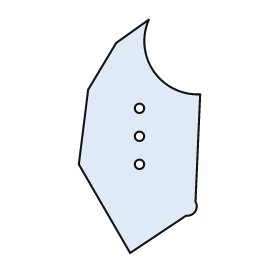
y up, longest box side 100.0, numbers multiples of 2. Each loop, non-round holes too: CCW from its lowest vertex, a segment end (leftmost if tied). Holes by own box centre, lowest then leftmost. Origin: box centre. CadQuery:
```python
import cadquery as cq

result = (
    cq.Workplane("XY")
    .moveTo(-4.0, -50.0)
    .lineTo(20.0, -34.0)
    .threePointArc((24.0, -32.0), (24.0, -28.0))
    .lineTo(26.0, 18.0)
    .threePointArc((6.0, 28.0), (4.0, 50.0))
    .lineTo(-10.0, 40.0)
    .lineTo(-22.0, 20.0)
    .lineTo(-26.0, -12.0)
    .close()
    .moveTo(0.0, -12.0)
    .circle(2.0)
    .moveTo(0.0, 0.0)
    .circle(2.0)
    .moveTo(0.0, 12.0)
    .circle(2.0)
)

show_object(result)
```